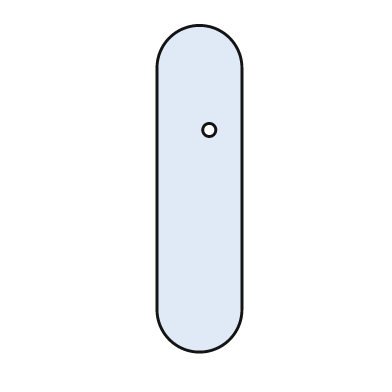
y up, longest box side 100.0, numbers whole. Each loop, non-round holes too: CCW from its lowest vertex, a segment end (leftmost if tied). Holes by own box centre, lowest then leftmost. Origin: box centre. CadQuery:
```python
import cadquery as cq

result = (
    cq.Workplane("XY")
    .moveTo(-13.0, -37.0)
    .threePointArc((0.0, -50.0), (13.0, -37.0))
    .lineTo(13.0, 37.0)
    .threePointArc((0.0, 50.0), (-13.0, 37.0))
    .close()
    .moveTo(3.0, 18.0)
    .circle(2.0)
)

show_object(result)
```